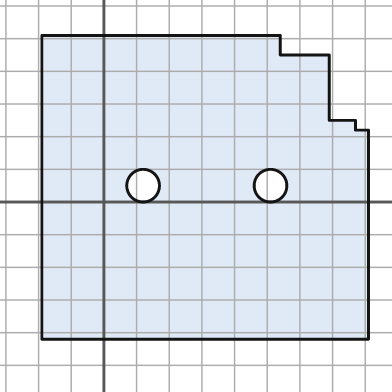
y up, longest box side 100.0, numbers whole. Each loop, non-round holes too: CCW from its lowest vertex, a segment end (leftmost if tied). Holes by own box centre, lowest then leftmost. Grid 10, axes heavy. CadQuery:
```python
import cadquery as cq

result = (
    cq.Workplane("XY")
    .moveTo(-19.0, -42.0)
    .lineTo(81.0, -42.0)
    .lineTo(81.0, 22.0)
    .lineTo(77.0, 22.0)
    .lineTo(77.0, 25.0)
    .lineTo(69.0, 25.0)
    .lineTo(69.0, 45.0)
    .lineTo(54.0, 45.0)
    .lineTo(54.0, 51.0)
    .lineTo(-19.0, 51.0)
    .close()
    .moveTo(12.0, 5.0)
    .circle(5.0)
    .moveTo(51.0, 5.0)
    .circle(5.0)
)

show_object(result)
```